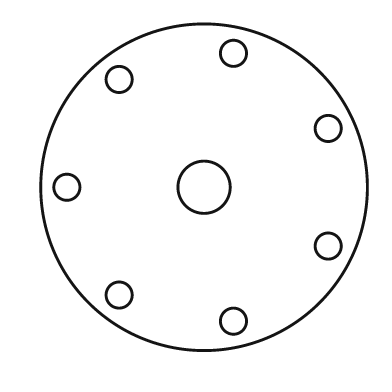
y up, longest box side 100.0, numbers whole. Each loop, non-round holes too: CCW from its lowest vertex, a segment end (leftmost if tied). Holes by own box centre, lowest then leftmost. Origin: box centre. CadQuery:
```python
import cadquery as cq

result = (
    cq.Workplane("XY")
    .moveTo(0.0, 0.0)
    .circle(50.0)
    .moveTo(9.0, -41.0)
    .circle(4.0)
    .moveTo(-26.0, -33.0)
    .circle(4.0)
    .moveTo(38.0, -18.0)
    .circle(4.0)
    .moveTo(-42.0, 0.0)
    .circle(4.0)
    .moveTo(0.0, 0.0)
    .circle(8.0)
    .moveTo(38.0, 18.0)
    .circle(4.0)
    .moveTo(-26.0, 33.0)
    .circle(4.0)
    .moveTo(9.0, 41.0)
    .circle(4.0)
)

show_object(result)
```